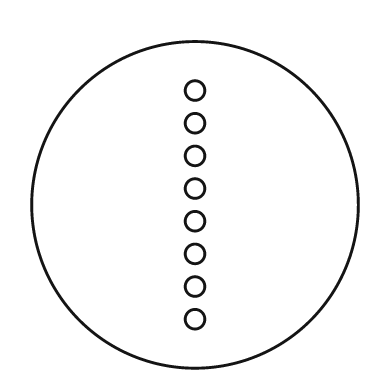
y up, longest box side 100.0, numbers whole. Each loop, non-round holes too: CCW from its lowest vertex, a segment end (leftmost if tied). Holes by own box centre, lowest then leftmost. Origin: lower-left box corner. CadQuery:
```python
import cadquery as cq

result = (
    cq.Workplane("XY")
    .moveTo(50.0, 50.0)
    .circle(50.0)
    .moveTo(50.0, 15.0)
    .circle(3.0)
    .moveTo(50.0, 25.0)
    .circle(3.0)
    .moveTo(50.0, 35.0)
    .circle(3.0)
    .moveTo(50.0, 45.0)
    .circle(3.0)
    .moveTo(50.0, 55.0)
    .circle(3.0)
    .moveTo(50.0, 65.0)
    .circle(3.0)
    .moveTo(50.0, 75.0)
    .circle(3.0)
    .moveTo(50.0, 85.0)
    .circle(3.0)
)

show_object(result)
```